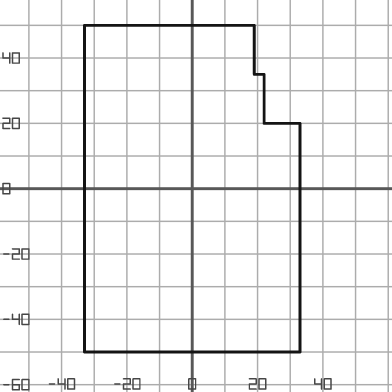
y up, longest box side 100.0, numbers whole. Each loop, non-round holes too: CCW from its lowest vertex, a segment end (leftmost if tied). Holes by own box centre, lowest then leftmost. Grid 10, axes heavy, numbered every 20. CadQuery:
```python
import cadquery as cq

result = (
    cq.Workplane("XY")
    .moveTo(-33.0, -50.0)
    .lineTo(33.0, -50.0)
    .lineTo(33.0, 20.0)
    .lineTo(22.0, 20.0)
    .lineTo(22.0, 35.0)
    .lineTo(19.0, 35.0)
    .lineTo(19.0, 50.0)
    .lineTo(-33.0, 50.0)
    .close()
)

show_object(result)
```